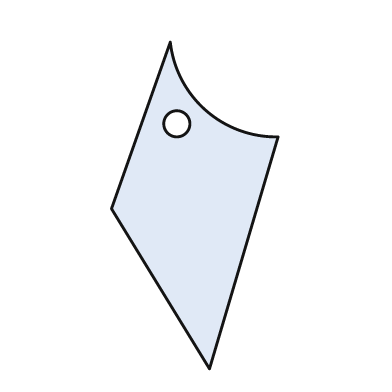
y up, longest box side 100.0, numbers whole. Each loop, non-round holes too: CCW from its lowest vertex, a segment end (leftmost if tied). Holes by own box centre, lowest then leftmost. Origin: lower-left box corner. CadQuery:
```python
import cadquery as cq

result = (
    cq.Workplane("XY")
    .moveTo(30.0, 0.0)
    .lineTo(51.0, 71.0)
    .threePointArc((29.0, 79.0), (18.0, 100.0))
    .lineTo(0.0, 49.0)
    .close()
    .moveTo(20.0, 75.0)
    .circle(4.0)
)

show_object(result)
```